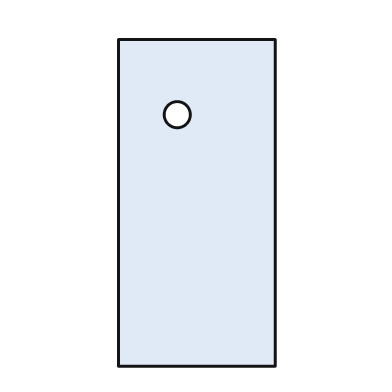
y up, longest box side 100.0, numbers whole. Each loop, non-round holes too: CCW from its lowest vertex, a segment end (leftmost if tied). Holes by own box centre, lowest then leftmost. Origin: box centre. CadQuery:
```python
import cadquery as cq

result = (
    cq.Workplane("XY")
    .moveTo(-24.0, -50.0)
    .lineTo(24.0, -50.0)
    .lineTo(24.0, 50.0)
    .lineTo(-24.0, 50.0)
    .close()
    .moveTo(-6.0, 27.0)
    .circle(4.0)
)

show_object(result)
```